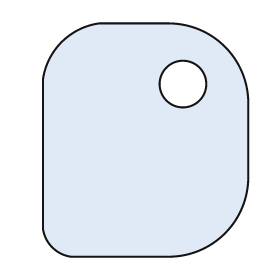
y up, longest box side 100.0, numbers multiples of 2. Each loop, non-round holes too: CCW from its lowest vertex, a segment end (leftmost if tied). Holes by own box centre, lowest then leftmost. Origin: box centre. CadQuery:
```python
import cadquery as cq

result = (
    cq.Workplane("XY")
    .moveTo(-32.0, -50.0)
    .lineTo(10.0, -50.0)
    .threePointArc((34.0, -40.0), (44.0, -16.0))
    .lineTo(44.0, 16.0)
    .threePointArc((34.0, 40.0), (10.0, 50.0))
    .lineTo(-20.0, 50.0)
    .threePointArc((-36.0, 42.0), (-44.0, 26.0))
    .lineTo(-44.0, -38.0)
    .threePointArc((-40.0, -46.0), (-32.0, -50.0))
    .close()
    .moveTo(16.0, 24.0)
    .circle(10.0)
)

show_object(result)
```